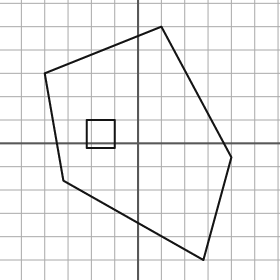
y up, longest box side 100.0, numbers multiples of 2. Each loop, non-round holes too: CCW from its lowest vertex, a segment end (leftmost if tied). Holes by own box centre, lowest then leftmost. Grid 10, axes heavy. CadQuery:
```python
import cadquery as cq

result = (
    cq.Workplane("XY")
    .moveTo(28.0, -50.0)
    .lineTo(40.0, -6.0)
    .lineTo(10.0, 50.0)
    .lineTo(-40.0, 30.0)
    .lineTo(-32.0, -16.0)
    .close()
    .moveTo(-22.0, -2.0)
    .lineTo(-10.0, -2.0)
    .lineTo(-10.0, 10.0)
    .lineTo(-22.0, 10.0)
    .close()
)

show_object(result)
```